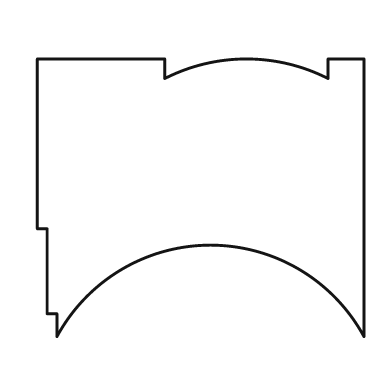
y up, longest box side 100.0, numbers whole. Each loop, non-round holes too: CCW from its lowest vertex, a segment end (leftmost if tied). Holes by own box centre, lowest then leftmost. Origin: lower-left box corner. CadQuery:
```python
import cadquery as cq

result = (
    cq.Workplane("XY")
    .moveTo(6.0, 0.0)
    .threePointArc((53.0, 28.0), (100.0, 0.0))
    .lineTo(100.0, 85.0)
    .lineTo(89.0, 85.0)
    .lineTo(89.0, 79.0)
    .threePointArc((64.0, 85.0), (39.0, 79.0))
    .lineTo(39.0, 85.0)
    .lineTo(0.0, 85.0)
    .lineTo(0.0, 33.0)
    .lineTo(3.0, 33.0)
    .lineTo(3.0, 7.0)
    .lineTo(6.0, 7.0)
    .close()
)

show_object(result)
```